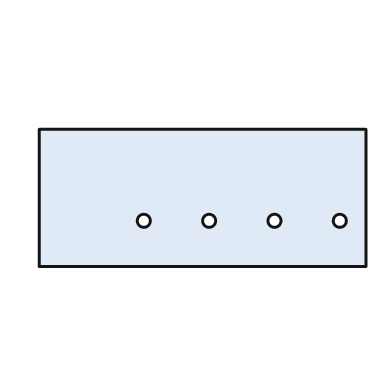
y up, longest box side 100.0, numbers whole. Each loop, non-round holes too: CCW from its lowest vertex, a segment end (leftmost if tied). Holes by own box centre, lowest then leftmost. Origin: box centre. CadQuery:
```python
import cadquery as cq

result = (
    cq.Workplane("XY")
    .moveTo(-50.0, -21.0)
    .lineTo(50.0, -21.0)
    .lineTo(50.0, 21.0)
    .lineTo(-50.0, 21.0)
    .close()
    .moveTo(-18.0, -7.0)
    .circle(2.0)
    .moveTo(2.0, -7.0)
    .circle(2.0)
    .moveTo(22.0, -7.0)
    .circle(2.0)
    .moveTo(42.0, -7.0)
    .circle(2.0)
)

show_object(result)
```